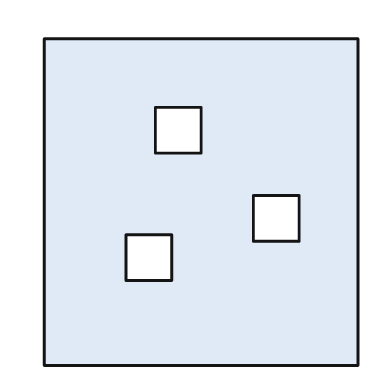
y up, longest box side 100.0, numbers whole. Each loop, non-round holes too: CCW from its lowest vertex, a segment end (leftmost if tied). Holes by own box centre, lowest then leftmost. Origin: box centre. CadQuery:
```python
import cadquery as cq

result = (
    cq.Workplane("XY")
    .moveTo(-48.0, -50.0)
    .lineTo(48.0, -50.0)
    .lineTo(48.0, 50.0)
    .lineTo(-48.0, 50.0)
    .close()
    .moveTo(-23.0, -24.0)
    .lineTo(-9.0, -24.0)
    .lineTo(-9.0, -10.0)
    .lineTo(-23.0, -10.0)
    .close()
    .moveTo(16.0, -12.0)
    .lineTo(30.0, -12.0)
    .lineTo(30.0, 2.0)
    .lineTo(16.0, 2.0)
    .close()
    .moveTo(-14.0, 15.0)
    .lineTo(0.0, 15.0)
    .lineTo(0.0, 29.0)
    .lineTo(-14.0, 29.0)
    .close()
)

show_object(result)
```